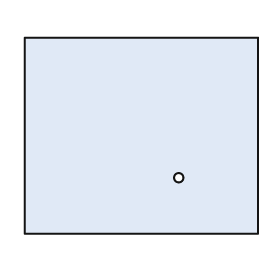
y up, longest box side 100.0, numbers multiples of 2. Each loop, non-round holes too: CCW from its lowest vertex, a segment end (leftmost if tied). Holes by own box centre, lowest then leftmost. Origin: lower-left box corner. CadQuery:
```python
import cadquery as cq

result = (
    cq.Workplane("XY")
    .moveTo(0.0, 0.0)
    .lineTo(100.0, 0.0)
    .lineTo(100.0, 84.0)
    .lineTo(0.0, 84.0)
    .close()
    .moveTo(66.0, 24.0)
    .circle(2.0)
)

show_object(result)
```